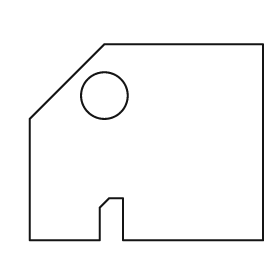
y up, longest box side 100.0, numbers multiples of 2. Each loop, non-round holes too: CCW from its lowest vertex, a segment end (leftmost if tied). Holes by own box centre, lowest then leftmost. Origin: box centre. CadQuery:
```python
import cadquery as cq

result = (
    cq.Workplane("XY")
    .moveTo(-50.0, -42.0)
    .lineTo(-20.0, -42.0)
    .lineTo(-20.0, -28.0)
    .lineTo(-16.0, -24.0)
    .lineTo(-10.0, -24.0)
    .lineTo(-10.0, -42.0)
    .lineTo(50.0, -42.0)
    .lineTo(50.0, 42.0)
    .lineTo(-18.0, 42.0)
    .lineTo(-50.0, 10.0)
    .close()
    .moveTo(-18.0, 20.0)
    .circle(10.0)
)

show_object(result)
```